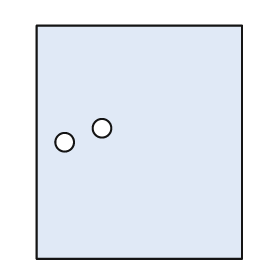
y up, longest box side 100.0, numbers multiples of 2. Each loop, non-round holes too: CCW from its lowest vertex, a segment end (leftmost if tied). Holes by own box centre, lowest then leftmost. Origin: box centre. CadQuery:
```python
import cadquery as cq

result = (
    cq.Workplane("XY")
    .moveTo(-44.0, -50.0)
    .lineTo(44.0, -50.0)
    .lineTo(44.0, 50.0)
    .lineTo(-44.0, 50.0)
    .close()
    .moveTo(-32.0, 0.0)
    .circle(4.0)
    .moveTo(-16.0, 6.0)
    .circle(4.0)
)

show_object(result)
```